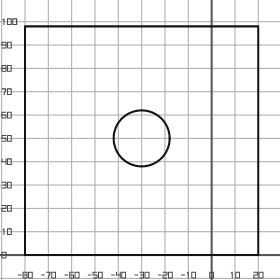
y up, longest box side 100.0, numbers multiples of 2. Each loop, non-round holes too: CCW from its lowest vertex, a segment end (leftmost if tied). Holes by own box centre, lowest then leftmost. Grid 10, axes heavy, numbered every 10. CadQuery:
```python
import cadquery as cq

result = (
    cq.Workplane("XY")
    .moveTo(-80.0, 0.0)
    .lineTo(20.0, 0.0)
    .lineTo(20.0, 98.0)
    .lineTo(-80.0, 98.0)
    .close()
    .moveTo(-30.0, 50.0)
    .circle(12.0)
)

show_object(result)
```